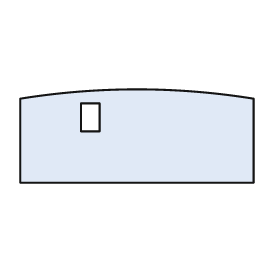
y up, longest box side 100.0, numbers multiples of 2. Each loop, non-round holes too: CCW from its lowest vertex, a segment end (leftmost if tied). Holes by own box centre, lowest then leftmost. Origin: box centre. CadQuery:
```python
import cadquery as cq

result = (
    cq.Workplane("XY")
    .moveTo(-50.0, -20.0)
    .lineTo(50.0, -20.0)
    .lineTo(50.0, 16.0)
    .threePointArc((0.0, 20.0), (-50.0, 16.0))
    .close()
    .moveTo(-24.0, 2.0)
    .lineTo(-16.0, 2.0)
    .lineTo(-16.0, 14.0)
    .lineTo(-24.0, 14.0)
    .close()
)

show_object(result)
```